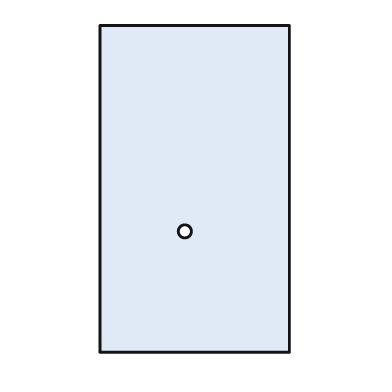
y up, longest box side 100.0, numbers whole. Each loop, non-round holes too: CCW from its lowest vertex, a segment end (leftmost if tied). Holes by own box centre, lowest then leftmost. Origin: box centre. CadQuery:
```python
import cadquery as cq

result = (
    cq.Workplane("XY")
    .moveTo(-29.0, -50.0)
    .lineTo(29.0, -50.0)
    .lineTo(29.0, 50.0)
    .lineTo(-29.0, 50.0)
    .close()
    .moveTo(-3.0, -13.0)
    .circle(2.0)
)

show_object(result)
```